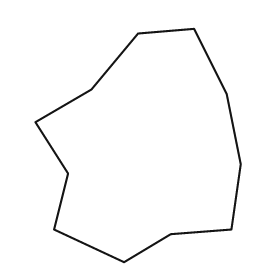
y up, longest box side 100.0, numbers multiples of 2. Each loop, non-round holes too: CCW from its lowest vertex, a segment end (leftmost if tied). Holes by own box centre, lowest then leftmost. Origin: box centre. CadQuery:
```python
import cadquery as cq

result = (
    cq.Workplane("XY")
    .moveTo(-6.0, -50.0)
    .lineTo(14.0, -38.0)
    .lineTo(40.0, -36.0)
    .lineTo(44.0, -8.0)
    .lineTo(38.0, 22.0)
    .lineTo(24.0, 50.0)
    .lineTo(0.0, 48.0)
    .lineTo(-20.0, 24.0)
    .lineTo(-44.0, 10.0)
    .lineTo(-30.0, -12.0)
    .lineTo(-36.0, -36.0)
    .close()
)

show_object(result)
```